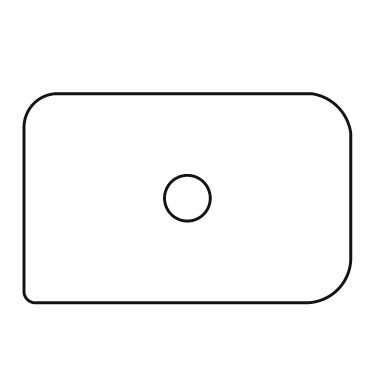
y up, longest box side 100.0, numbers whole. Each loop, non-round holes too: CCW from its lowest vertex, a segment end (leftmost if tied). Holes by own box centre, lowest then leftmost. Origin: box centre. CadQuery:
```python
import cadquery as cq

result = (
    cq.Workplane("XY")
    .moveTo(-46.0, -32.0)
    .lineTo(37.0, -32.0)
    .threePointArc((46.0, -28.0), (50.0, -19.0))
    .lineTo(50.0, 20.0)
    .threePointArc((46.0, 28.0), (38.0, 32.0))
    .lineTo(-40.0, 32.0)
    .threePointArc((-47.0, 29.0), (-50.0, 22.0))
    .lineTo(-50.0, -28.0)
    .threePointArc((-49.0, -31.0), (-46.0, -32.0))
    .close()
    .moveTo(0.0, 0.0)
    .circle(7.0)
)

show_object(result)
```